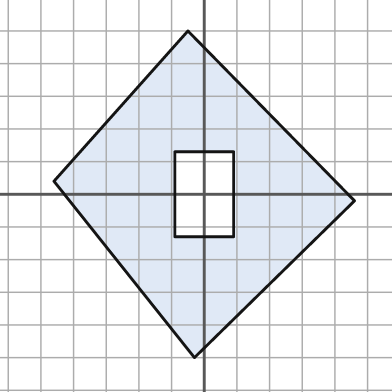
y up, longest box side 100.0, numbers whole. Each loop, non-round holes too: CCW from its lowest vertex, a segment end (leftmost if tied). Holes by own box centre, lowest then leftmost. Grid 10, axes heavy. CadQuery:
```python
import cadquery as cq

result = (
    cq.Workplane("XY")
    .moveTo(-3.0, -50.0)
    .lineTo(46.0, -2.0)
    .lineTo(-5.0, 50.0)
    .lineTo(-46.0, 4.0)
    .close()
    .moveTo(-9.0, -13.0)
    .lineTo(9.0, -13.0)
    .lineTo(9.0, 13.0)
    .lineTo(-9.0, 13.0)
    .close()
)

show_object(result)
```